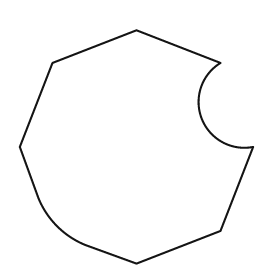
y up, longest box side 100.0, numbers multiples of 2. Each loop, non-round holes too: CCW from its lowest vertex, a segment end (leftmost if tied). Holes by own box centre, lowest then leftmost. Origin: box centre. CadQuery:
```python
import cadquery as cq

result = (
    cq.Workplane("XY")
    .moveTo(0.0, -50.0)
    .lineTo(36.0, -36.0)
    .lineTo(50.0, 0.0)
    .threePointArc((28.0, 12.0), (36.0, 36.0))
    .lineTo(0.0, 50.0)
    .lineTo(-36.0, 36.0)
    .lineTo(-50.0, 0.0)
    .lineTo(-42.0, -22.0)
    .threePointArc((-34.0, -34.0), (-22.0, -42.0))
    .close()
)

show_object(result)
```